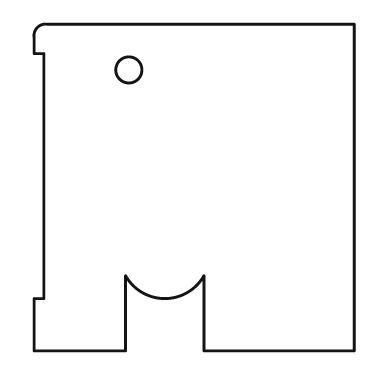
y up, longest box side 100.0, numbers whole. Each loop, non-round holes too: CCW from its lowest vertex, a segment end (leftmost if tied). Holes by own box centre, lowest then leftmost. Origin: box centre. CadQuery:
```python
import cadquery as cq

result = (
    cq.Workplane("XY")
    .moveTo(-49.0, -50.0)
    .lineTo(-21.0, -50.0)
    .lineTo(-21.0, -27.0)
    .threePointArc((-9.0, -34.0), (3.0, -27.0))
    .lineTo(3.0, -50.0)
    .lineTo(49.0, -50.0)
    .lineTo(49.0, 50.0)
    .lineTo(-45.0, 50.0)
    .threePointArc((-48.0, 49.0), (-49.0, 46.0))
    .lineTo(-49.0, 41.0)
    .lineTo(-46.0, 41.0)
    .lineTo(-46.0, -34.0)
    .lineTo(-49.0, -34.0)
    .close()
    .moveTo(-20.0, 36.0)
    .circle(4.0)
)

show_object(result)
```